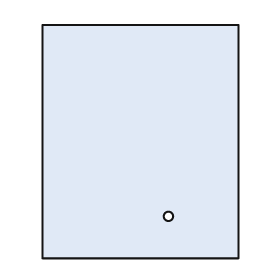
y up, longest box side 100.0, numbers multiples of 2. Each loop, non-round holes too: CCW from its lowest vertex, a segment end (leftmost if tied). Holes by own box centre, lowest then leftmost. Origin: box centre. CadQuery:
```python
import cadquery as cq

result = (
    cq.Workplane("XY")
    .moveTo(-42.0, -50.0)
    .lineTo(42.0, -50.0)
    .lineTo(42.0, 50.0)
    .lineTo(-42.0, 50.0)
    .close()
    .moveTo(12.0, -32.0)
    .circle(2.0)
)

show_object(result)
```